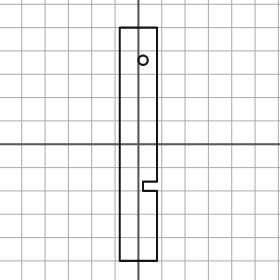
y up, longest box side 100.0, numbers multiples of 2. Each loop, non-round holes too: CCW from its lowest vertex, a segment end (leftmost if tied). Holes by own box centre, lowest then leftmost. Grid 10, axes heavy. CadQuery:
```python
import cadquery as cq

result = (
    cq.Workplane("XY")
    .moveTo(-8.0, -50.0)
    .lineTo(8.0, -50.0)
    .lineTo(8.0, -20.0)
    .lineTo(2.0, -20.0)
    .lineTo(2.0, -16.0)
    .lineTo(8.0, -16.0)
    .lineTo(8.0, 50.0)
    .lineTo(-8.0, 50.0)
    .close()
    .moveTo(2.0, 36.0)
    .circle(2.0)
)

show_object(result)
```